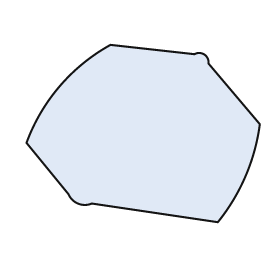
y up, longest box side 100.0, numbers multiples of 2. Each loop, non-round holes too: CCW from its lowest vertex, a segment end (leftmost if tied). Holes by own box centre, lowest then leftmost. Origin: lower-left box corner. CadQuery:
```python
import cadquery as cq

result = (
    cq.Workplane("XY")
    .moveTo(82.0, 0.0)
    .threePointArc((94.0, 20.0), (100.0, 42.0))
    .lineTo(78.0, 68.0)
    .threePointArc((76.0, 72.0), (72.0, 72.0))
    .lineTo(36.0, 76.0)
    .threePointArc((14.0, 58.0), (0.0, 34.0))
    .lineTo(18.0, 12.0)
    .threePointArc((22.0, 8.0), (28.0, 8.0))
    .close()
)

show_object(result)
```